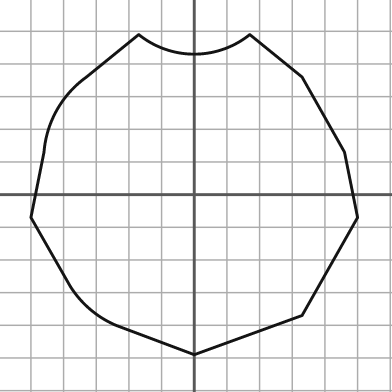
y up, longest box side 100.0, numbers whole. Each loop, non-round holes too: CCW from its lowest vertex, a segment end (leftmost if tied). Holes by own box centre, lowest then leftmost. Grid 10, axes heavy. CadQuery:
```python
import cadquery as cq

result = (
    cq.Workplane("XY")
    .moveTo(0.0, -49.0)
    .lineTo(33.0, -37.0)
    .lineTo(50.0, -7.0)
    .lineTo(46.0, 13.0)
    .lineTo(33.0, 36.0)
    .lineTo(17.0, 49.0)
    .threePointArc((0.0, 43.0), (-17.0, 49.0))
    .lineTo(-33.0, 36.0)
    .threePointArc((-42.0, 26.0), (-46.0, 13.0))
    .lineTo(-50.0, -7.0)
    .lineTo(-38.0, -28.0)
    .threePointArc((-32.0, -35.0), (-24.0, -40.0))
    .close()
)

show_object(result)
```